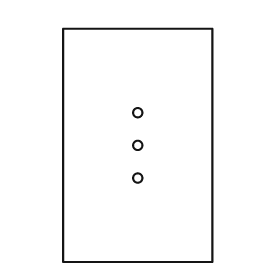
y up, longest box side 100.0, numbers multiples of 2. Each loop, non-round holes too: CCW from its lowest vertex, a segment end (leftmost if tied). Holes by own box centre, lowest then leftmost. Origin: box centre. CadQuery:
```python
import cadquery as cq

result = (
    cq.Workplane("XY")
    .moveTo(-32.0, -50.0)
    .lineTo(32.0, -50.0)
    .lineTo(32.0, 50.0)
    .lineTo(-32.0, 50.0)
    .close()
    .moveTo(0.0, -14.0)
    .circle(2.0)
    .moveTo(0.0, 0.0)
    .circle(2.0)
    .moveTo(0.0, 14.0)
    .circle(2.0)
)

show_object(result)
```